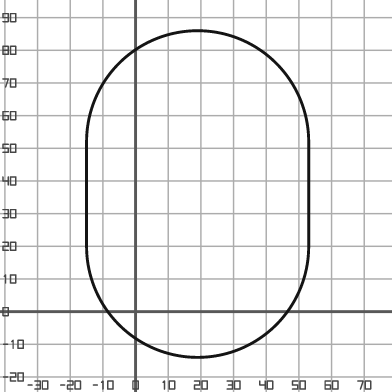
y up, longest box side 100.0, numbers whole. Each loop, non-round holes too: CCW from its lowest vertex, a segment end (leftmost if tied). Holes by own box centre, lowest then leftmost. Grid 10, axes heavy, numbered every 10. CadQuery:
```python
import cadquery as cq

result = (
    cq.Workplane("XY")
    .moveTo(-15.0, 20.0)
    .threePointArc((19.0, -14.0), (53.0, 20.0))
    .lineTo(53.0, 52.0)
    .threePointArc((19.0, 86.0), (-15.0, 52.0))
    .close()
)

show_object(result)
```